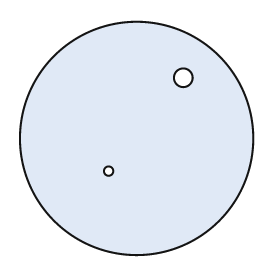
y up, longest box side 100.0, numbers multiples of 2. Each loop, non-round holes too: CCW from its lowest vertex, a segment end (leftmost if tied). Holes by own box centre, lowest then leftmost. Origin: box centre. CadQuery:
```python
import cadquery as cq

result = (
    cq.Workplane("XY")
    .moveTo(0.0, 0.0)
    .circle(50.0)
    .moveTo(-12.0, -14.0)
    .circle(2.0)
    .moveTo(20.0, 26.0)
    .circle(4.0)
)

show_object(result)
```